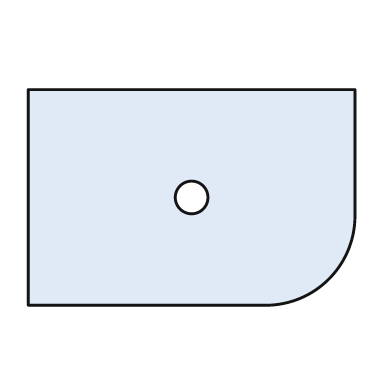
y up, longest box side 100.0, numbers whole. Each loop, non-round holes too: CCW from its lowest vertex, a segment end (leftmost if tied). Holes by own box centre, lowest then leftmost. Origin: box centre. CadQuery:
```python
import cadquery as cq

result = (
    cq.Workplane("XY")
    .moveTo(-50.0, -33.0)
    .lineTo(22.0, -33.0)
    .threePointArc((42.0, -25.0), (50.0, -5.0))
    .lineTo(50.0, 33.0)
    .lineTo(-50.0, 33.0)
    .close()
    .moveTo(0.0, 0.0)
    .circle(5.0)
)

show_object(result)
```